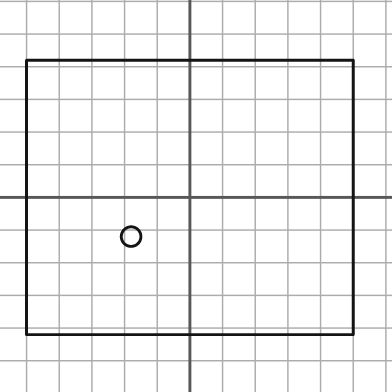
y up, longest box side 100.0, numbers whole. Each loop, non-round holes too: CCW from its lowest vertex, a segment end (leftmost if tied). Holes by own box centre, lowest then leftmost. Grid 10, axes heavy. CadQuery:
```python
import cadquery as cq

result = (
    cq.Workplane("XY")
    .moveTo(-50.0, -42.0)
    .lineTo(50.0, -42.0)
    .lineTo(50.0, 42.0)
    .lineTo(-50.0, 42.0)
    .close()
    .moveTo(-18.0, -12.0)
    .circle(3.0)
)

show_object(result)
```